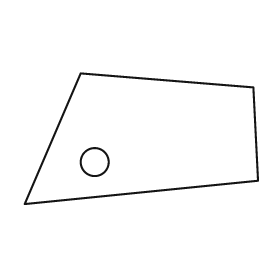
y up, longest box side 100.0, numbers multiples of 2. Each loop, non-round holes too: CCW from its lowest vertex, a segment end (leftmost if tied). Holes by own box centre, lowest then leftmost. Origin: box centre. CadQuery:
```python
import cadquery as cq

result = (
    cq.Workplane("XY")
    .moveTo(-50.0, -28.0)
    .lineTo(50.0, -18.0)
    .lineTo(48.0, 22.0)
    .lineTo(-26.0, 28.0)
    .close()
    .moveTo(-20.0, -10.0)
    .circle(6.0)
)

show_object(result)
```